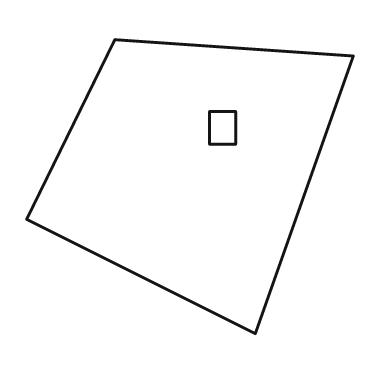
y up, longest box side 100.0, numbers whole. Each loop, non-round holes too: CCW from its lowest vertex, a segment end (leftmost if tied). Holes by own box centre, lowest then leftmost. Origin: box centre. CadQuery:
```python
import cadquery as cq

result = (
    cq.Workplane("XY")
    .moveTo(20.0, -45.0)
    .lineTo(50.0, 40.0)
    .lineTo(-23.0, 45.0)
    .lineTo(-50.0, -10.0)
    .close()
    .moveTo(6.0, 13.0)
    .lineTo(14.0, 13.0)
    .lineTo(14.0, 23.0)
    .lineTo(6.0, 23.0)
    .close()
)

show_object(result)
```